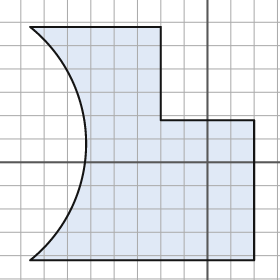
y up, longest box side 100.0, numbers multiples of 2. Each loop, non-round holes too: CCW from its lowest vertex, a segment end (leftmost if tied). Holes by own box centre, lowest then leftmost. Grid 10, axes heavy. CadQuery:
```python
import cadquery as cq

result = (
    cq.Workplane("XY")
    .moveTo(-76.0, -42.0)
    .lineTo(20.0, -42.0)
    .lineTo(20.0, 18.0)
    .lineTo(-20.0, 18.0)
    .lineTo(-20.0, 58.0)
    .lineTo(-76.0, 58.0)
    .threePointArc((-52.0, 8.0), (-76.0, -42.0))
    .close()
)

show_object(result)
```